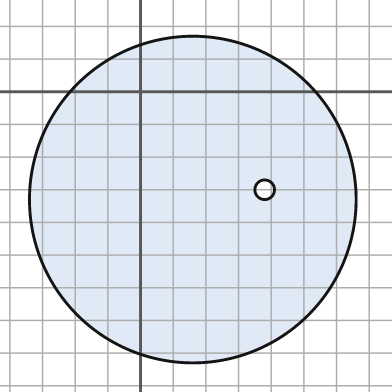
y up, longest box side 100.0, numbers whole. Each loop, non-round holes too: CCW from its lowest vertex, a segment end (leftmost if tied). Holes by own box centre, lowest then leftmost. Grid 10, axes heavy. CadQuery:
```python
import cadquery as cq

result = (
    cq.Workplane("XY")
    .moveTo(16.0, -33.0)
    .circle(50.0)
    .moveTo(38.0, -30.0)
    .circle(3.0)
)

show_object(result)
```